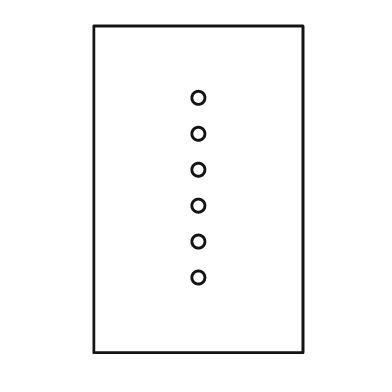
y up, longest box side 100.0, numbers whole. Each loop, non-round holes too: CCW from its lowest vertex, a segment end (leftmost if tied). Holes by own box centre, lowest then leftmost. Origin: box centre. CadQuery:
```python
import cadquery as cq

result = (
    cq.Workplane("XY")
    .moveTo(-32.0, -50.0)
    .lineTo(32.0, -50.0)
    .lineTo(32.0, 50.0)
    .lineTo(-32.0, 50.0)
    .close()
    .moveTo(0.0, -27.0)
    .circle(2.0)
    .moveTo(0.0, -16.0)
    .circle(2.0)
    .moveTo(0.0, -5.0)
    .circle(2.0)
    .moveTo(0.0, 6.0)
    .circle(2.0)
    .moveTo(0.0, 17.0)
    .circle(2.0)
    .moveTo(0.0, 28.0)
    .circle(2.0)
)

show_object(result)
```